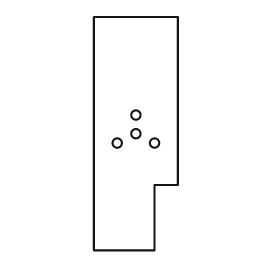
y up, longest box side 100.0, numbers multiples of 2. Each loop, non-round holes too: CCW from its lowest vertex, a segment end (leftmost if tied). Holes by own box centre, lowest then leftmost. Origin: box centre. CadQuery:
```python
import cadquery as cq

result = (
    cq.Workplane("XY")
    .moveTo(-18.0, -50.0)
    .lineTo(8.0, -50.0)
    .lineTo(8.0, -22.0)
    .lineTo(18.0, -22.0)
    .lineTo(18.0, 50.0)
    .lineTo(-18.0, 50.0)
    .close()
    .moveTo(-8.0, -4.0)
    .circle(2.0)
    .moveTo(8.0, -4.0)
    .circle(2.0)
    .moveTo(0.0, 0.0)
    .circle(2.0)
    .moveTo(0.0, 8.0)
    .circle(2.0)
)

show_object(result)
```